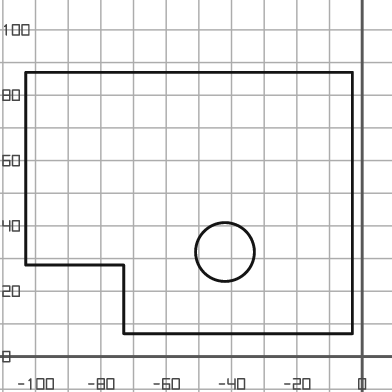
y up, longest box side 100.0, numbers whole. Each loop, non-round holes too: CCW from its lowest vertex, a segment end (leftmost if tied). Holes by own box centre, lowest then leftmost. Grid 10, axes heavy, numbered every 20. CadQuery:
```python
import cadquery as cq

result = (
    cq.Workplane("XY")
    .moveTo(-73.0, 7.0)
    .lineTo(-3.0, 7.0)
    .lineTo(-3.0, 87.0)
    .lineTo(-103.0, 87.0)
    .lineTo(-103.0, 28.0)
    .lineTo(-73.0, 28.0)
    .close()
    .moveTo(-42.0, 32.0)
    .circle(9.0)
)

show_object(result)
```